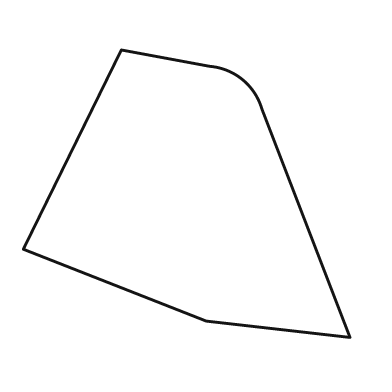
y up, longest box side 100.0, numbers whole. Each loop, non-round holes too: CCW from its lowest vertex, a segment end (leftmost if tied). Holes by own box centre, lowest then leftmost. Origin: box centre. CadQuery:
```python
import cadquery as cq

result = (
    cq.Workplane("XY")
    .moveTo(50.0, -44.0)
    .lineTo(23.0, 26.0)
    .threePointArc((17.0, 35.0), (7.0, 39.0))
    .lineTo(-20.0, 44.0)
    .lineTo(-50.0, -17.0)
    .lineTo(6.0, -39.0)
    .close()
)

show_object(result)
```